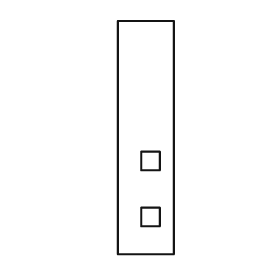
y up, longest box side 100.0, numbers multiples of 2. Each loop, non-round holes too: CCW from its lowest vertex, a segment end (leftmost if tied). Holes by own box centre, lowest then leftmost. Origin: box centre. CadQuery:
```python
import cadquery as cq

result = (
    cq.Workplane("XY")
    .moveTo(-12.0, -50.0)
    .lineTo(12.0, -50.0)
    .lineTo(12.0, 50.0)
    .lineTo(-12.0, 50.0)
    .close()
    .moveTo(-2.0, -38.0)
    .lineTo(6.0, -38.0)
    .lineTo(6.0, -30.0)
    .lineTo(-2.0, -30.0)
    .close()
    .moveTo(-2.0, -14.0)
    .lineTo(6.0, -14.0)
    .lineTo(6.0, -6.0)
    .lineTo(-2.0, -6.0)
    .close()
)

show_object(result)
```